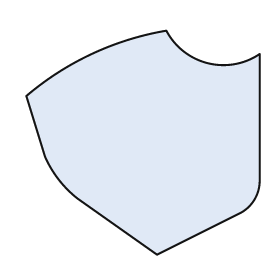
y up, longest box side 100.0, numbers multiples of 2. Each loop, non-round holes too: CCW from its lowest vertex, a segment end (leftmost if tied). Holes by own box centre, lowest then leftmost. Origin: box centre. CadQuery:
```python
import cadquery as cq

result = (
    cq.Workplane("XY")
    .moveTo(6.0, -48.0)
    .lineTo(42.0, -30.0)
    .threePointArc((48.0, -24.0), (50.0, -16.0))
    .lineTo(50.0, 38.0)
    .threePointArc((28.0, 34.0), (10.0, 48.0))
    .threePointArc((-22.0, 38.0), (-50.0, 20.0))
    .lineTo(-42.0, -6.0)
    .threePointArc((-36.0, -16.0), (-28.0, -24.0))
    .close()
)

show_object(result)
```